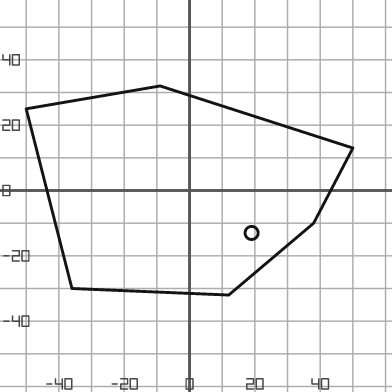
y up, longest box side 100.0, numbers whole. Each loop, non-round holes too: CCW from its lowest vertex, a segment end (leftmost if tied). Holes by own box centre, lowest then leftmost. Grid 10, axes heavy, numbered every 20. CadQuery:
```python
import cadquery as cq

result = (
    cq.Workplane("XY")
    .moveTo(12.0, -32.0)
    .lineTo(38.0, -10.0)
    .lineTo(50.0, 13.0)
    .lineTo(-9.0, 32.0)
    .lineTo(-50.0, 25.0)
    .lineTo(-36.0, -30.0)
    .close()
    .moveTo(19.0, -13.0)
    .circle(2.0)
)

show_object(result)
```